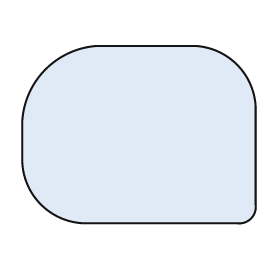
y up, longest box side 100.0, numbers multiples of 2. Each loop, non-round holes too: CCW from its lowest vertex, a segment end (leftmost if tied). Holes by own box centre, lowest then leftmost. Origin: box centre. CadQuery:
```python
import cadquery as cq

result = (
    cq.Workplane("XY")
    .moveTo(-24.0, -38.0)
    .lineTo(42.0, -38.0)
    .threePointArc((48.0, -36.0), (50.0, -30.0))
    .lineTo(50.0, 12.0)
    .threePointArc((42.0, 30.0), (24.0, 38.0))
    .lineTo(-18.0, 38.0)
    .threePointArc((-40.0, 28.0), (-50.0, 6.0))
    .lineTo(-50.0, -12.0)
    .threePointArc((-42.0, -30.0), (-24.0, -38.0))
    .close()
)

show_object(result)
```